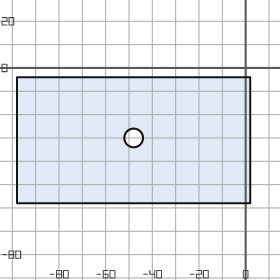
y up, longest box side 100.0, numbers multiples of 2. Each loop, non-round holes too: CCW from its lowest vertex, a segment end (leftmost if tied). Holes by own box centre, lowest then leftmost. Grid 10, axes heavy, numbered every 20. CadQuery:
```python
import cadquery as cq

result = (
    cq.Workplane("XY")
    .moveTo(-98.0, -58.0)
    .lineTo(2.0, -58.0)
    .lineTo(2.0, -4.0)
    .lineTo(-98.0, -4.0)
    .close()
    .moveTo(-48.0, -30.0)
    .circle(4.0)
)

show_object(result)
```